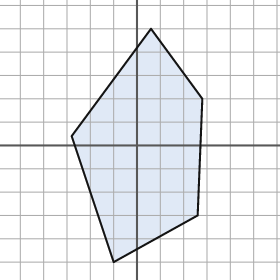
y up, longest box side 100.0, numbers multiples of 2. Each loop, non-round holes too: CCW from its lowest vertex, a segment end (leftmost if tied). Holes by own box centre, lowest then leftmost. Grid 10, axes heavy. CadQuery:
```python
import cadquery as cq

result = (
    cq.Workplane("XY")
    .moveTo(-10.0, -50.0)
    .lineTo(26.0, -30.0)
    .lineTo(28.0, 20.0)
    .lineTo(6.0, 50.0)
    .lineTo(-28.0, 4.0)
    .close()
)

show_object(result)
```